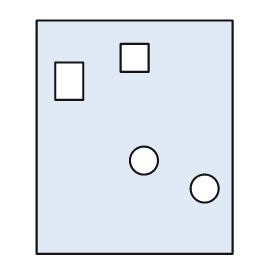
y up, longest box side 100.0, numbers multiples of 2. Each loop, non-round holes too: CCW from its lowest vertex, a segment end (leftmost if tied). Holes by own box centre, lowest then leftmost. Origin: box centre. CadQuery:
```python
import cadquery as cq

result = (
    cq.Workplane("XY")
    .moveTo(-42.0, -50.0)
    .lineTo(42.0, -50.0)
    .lineTo(42.0, 50.0)
    .lineTo(-42.0, 50.0)
    .close()
    .moveTo(30.0, -22.0)
    .circle(6.0)
    .moveTo(4.0, -10.0)
    .circle(6.0)
    .moveTo(-34.0, 16.0)
    .lineTo(-22.0, 16.0)
    .lineTo(-22.0, 32.0)
    .lineTo(-34.0, 32.0)
    .close()
    .moveTo(-6.0, 28.0)
    .lineTo(6.0, 28.0)
    .lineTo(6.0, 40.0)
    .lineTo(-6.0, 40.0)
    .close()
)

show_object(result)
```